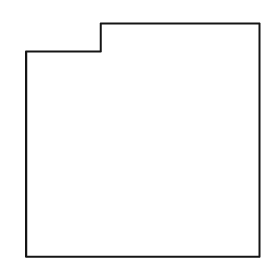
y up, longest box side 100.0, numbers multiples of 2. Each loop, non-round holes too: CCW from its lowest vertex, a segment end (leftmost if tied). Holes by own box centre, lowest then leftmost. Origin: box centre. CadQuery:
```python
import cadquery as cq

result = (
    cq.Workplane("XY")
    .moveTo(-50.0, -50.0)
    .lineTo(50.0, -50.0)
    .lineTo(50.0, 50.0)
    .lineTo(-18.0, 50.0)
    .lineTo(-18.0, 38.0)
    .lineTo(-50.0, 38.0)
    .close()
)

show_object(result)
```